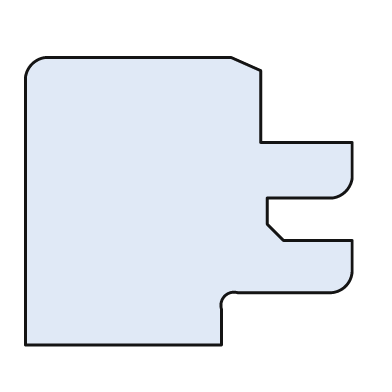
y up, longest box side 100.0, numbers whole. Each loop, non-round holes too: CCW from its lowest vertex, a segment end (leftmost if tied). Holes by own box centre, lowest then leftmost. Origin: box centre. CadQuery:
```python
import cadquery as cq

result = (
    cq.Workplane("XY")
    .moveTo(-50.0, -44.0)
    .lineTo(10.0, -44.0)
    .lineTo(10.0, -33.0)
    .threePointArc((11.0, -29.0), (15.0, -28.0))
    .lineTo(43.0, -28.0)
    .threePointArc((48.0, -26.0), (50.0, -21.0))
    .lineTo(50.0, -12.0)
    .lineTo(29.0, -12.0)
    .lineTo(24.0, -7.0)
    .lineTo(24.0, 1.0)
    .lineTo(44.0, 1.0)
    .threePointArc((48.0, 3.0), (50.0, 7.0))
    .lineTo(50.0, 18.0)
    .lineTo(22.0, 18.0)
    .lineTo(22.0, 40.0)
    .lineTo(13.0, 44.0)
    .lineTo(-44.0, 44.0)
    .threePointArc((-48.0, 42.0), (-50.0, 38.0))
    .close()
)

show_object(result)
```